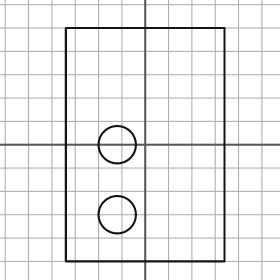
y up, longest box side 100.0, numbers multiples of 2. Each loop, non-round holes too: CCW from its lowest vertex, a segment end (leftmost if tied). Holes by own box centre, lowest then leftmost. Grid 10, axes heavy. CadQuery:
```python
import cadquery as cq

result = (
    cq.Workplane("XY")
    .moveTo(-34.0, -50.0)
    .lineTo(34.0, -50.0)
    .lineTo(34.0, 50.0)
    .lineTo(-34.0, 50.0)
    .close()
    .moveTo(-12.0, -30.0)
    .circle(8.0)
    .moveTo(-12.0, 0.0)
    .circle(8.0)
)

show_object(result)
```